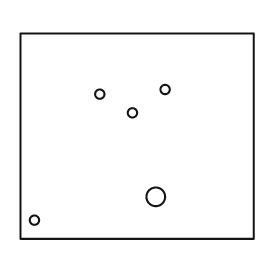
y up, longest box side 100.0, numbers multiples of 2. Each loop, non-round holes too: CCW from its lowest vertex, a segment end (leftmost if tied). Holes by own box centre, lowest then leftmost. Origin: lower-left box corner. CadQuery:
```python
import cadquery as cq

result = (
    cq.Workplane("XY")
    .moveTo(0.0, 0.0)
    .lineTo(100.0, 0.0)
    .lineTo(100.0, 88.0)
    .lineTo(0.0, 88.0)
    .close()
    .moveTo(6.0, 8.0)
    .circle(2.0)
    .moveTo(58.0, 18.0)
    .circle(4.0)
    .moveTo(48.0, 54.0)
    .circle(2.0)
    .moveTo(34.0, 62.0)
    .circle(2.0)
    .moveTo(62.0, 64.0)
    .circle(2.0)
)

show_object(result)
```